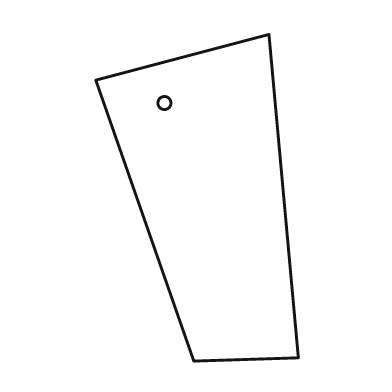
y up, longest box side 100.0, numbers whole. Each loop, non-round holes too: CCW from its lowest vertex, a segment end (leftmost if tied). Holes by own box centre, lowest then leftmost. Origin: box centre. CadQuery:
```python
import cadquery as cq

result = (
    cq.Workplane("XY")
    .moveTo(-1.0, -50.0)
    .lineTo(31.0, -49.0)
    .lineTo(22.0, 50.0)
    .lineTo(-31.0, 36.0)
    .close()
    .moveTo(-10.0, 29.0)
    .circle(2.0)
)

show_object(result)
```